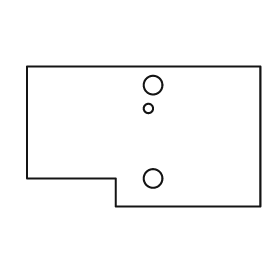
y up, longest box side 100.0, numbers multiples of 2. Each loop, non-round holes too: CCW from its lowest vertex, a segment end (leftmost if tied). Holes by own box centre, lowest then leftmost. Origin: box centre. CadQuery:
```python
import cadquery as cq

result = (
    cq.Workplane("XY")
    .moveTo(-12.0, -30.0)
    .lineTo(50.0, -30.0)
    .lineTo(50.0, 30.0)
    .lineTo(-50.0, 30.0)
    .lineTo(-50.0, -18.0)
    .lineTo(-12.0, -18.0)
    .close()
    .moveTo(4.0, -18.0)
    .circle(4.0)
    .moveTo(2.0, 12.0)
    .circle(2.0)
    .moveTo(4.0, 22.0)
    .circle(4.0)
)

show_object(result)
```